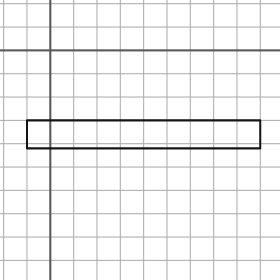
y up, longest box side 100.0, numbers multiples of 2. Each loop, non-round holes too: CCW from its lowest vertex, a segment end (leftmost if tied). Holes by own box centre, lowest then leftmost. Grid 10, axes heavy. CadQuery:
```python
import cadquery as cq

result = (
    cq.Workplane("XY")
    .moveTo(-10.0, -42.0)
    .lineTo(90.0, -42.0)
    .lineTo(90.0, -30.0)
    .lineTo(-10.0, -30.0)
    .close()
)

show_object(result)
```